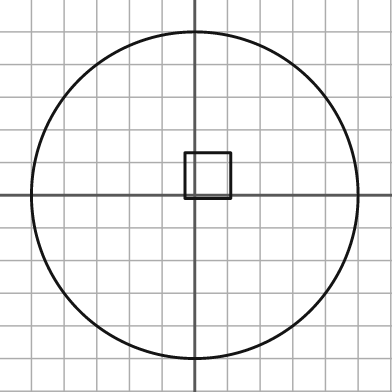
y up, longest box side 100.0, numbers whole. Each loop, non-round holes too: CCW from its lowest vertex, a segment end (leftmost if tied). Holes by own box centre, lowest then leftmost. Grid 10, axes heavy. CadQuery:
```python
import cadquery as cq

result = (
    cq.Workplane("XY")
    .moveTo(0.0, 0.0)
    .circle(50.0)
    .moveTo(-3.0, -1.0)
    .lineTo(11.0, -1.0)
    .lineTo(11.0, 13.0)
    .lineTo(-3.0, 13.0)
    .close()
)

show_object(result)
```